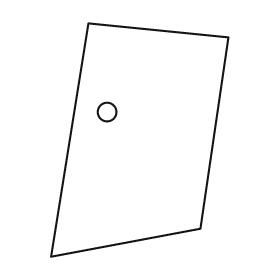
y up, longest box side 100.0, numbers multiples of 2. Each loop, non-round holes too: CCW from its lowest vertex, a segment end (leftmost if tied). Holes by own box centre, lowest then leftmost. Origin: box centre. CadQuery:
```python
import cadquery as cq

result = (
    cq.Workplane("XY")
    .moveTo(-38.0, -50.0)
    .lineTo(26.0, -38.0)
    .lineTo(38.0, 44.0)
    .lineTo(-22.0, 50.0)
    .close()
    .moveTo(-14.0, 12.0)
    .circle(4.0)
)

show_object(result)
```